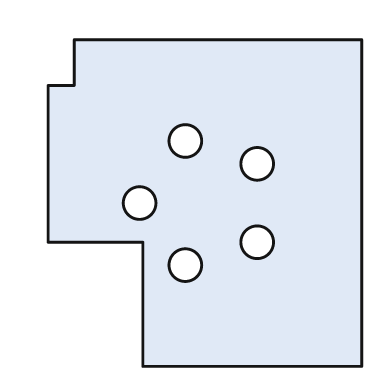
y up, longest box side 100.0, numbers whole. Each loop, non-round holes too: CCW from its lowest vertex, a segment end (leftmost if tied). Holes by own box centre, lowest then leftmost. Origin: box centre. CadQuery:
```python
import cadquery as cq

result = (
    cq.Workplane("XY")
    .moveTo(-19.0, -50.0)
    .lineTo(48.0, -50.0)
    .lineTo(48.0, 50.0)
    .lineTo(-40.0, 50.0)
    .lineTo(-40.0, 36.0)
    .lineTo(-48.0, 36.0)
    .lineTo(-48.0, -12.0)
    .lineTo(-19.0, -12.0)
    .close()
    .moveTo(-6.0, -19.0)
    .circle(5.0)
    .moveTo(16.0, -12.0)
    .circle(5.0)
    .moveTo(-20.0, 0.0)
    .circle(5.0)
    .moveTo(16.0, 12.0)
    .circle(5.0)
    .moveTo(-6.0, 19.0)
    .circle(5.0)
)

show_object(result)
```